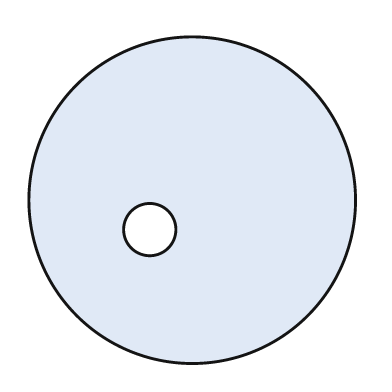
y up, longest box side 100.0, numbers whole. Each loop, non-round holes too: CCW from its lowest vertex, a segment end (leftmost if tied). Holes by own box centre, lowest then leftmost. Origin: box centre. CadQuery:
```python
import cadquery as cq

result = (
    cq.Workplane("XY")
    .moveTo(0.0, 0.0)
    .circle(50.0)
    .moveTo(-13.0, -9.0)
    .circle(8.0)
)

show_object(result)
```